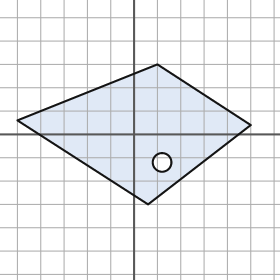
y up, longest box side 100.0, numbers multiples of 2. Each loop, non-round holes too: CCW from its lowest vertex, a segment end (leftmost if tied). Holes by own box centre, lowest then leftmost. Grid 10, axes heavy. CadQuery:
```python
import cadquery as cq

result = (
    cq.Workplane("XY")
    .moveTo(6.0, -30.0)
    .lineTo(50.0, 4.0)
    .lineTo(10.0, 30.0)
    .lineTo(-50.0, 6.0)
    .close()
    .moveTo(12.0, -12.0)
    .circle(4.0)
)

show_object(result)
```